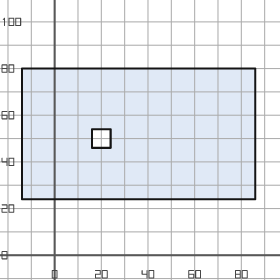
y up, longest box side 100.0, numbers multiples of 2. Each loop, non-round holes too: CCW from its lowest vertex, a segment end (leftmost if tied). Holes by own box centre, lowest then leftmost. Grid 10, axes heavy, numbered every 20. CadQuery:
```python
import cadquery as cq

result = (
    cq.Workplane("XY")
    .moveTo(-14.0, 24.0)
    .lineTo(86.0, 24.0)
    .lineTo(86.0, 80.0)
    .lineTo(-14.0, 80.0)
    .close()
    .moveTo(16.0, 46.0)
    .lineTo(24.0, 46.0)
    .lineTo(24.0, 54.0)
    .lineTo(16.0, 54.0)
    .close()
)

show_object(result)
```